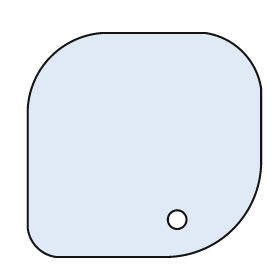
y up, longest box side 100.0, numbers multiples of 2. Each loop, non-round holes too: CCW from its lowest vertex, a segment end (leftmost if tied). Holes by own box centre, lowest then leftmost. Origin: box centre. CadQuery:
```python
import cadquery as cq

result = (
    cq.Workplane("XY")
    .moveTo(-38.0, -48.0)
    .lineTo(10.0, -48.0)
    .threePointArc((38.0, -36.0), (50.0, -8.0))
    .lineTo(50.0, 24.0)
    .threePointArc((42.0, 40.0), (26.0, 48.0))
    .lineTo(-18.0, 48.0)
    .threePointArc((-40.0, 38.0), (-50.0, 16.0))
    .lineTo(-50.0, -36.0)
    .threePointArc((-46.0, -44.0), (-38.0, -48.0))
    .close()
    .moveTo(14.0, -32.0)
    .circle(4.0)
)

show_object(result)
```